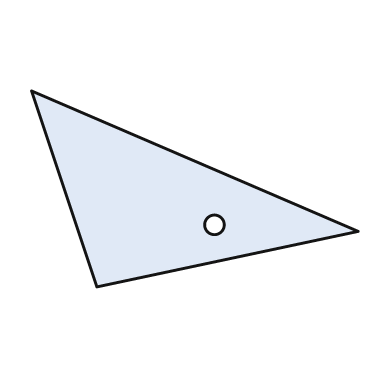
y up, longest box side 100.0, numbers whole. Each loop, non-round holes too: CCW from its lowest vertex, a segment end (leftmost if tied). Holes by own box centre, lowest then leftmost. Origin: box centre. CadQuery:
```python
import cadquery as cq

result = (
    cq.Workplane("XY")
    .moveTo(-30.0, -30.0)
    .lineTo(50.0, -13.0)
    .lineTo(-50.0, 30.0)
    .close()
    .moveTo(6.0, -11.0)
    .circle(3.0)
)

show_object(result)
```